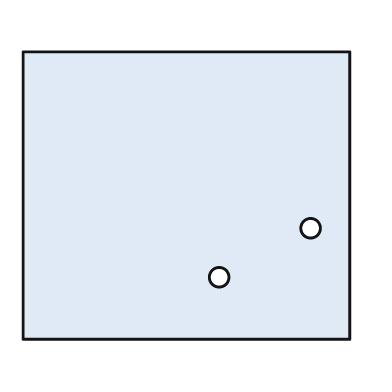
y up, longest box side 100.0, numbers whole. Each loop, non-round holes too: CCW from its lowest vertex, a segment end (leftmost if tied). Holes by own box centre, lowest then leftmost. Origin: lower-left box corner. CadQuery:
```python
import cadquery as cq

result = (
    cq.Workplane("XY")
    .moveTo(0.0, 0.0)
    .lineTo(100.0, 0.0)
    .lineTo(100.0, 88.0)
    .lineTo(0.0, 88.0)
    .close()
    .moveTo(60.0, 19.0)
    .circle(3.0)
    .moveTo(88.0, 34.0)
    .circle(3.0)
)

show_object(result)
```